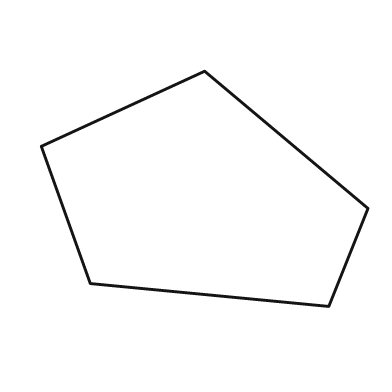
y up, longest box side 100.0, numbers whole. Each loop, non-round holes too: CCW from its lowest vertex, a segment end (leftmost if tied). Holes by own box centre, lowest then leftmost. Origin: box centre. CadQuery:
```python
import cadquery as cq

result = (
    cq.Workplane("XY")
    .moveTo(38.0, -36.0)
    .lineTo(50.0, -6.0)
    .lineTo(0.0, 36.0)
    .lineTo(-50.0, 13.0)
    .lineTo(-35.0, -29.0)
    .close()
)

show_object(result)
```